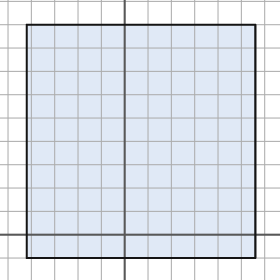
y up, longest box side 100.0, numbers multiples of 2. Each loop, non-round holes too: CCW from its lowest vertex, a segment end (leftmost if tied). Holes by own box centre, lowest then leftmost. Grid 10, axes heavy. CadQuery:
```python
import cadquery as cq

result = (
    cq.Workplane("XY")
    .moveTo(-42.0, -10.0)
    .lineTo(56.0, -10.0)
    .lineTo(56.0, 90.0)
    .lineTo(-42.0, 90.0)
    .close()
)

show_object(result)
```